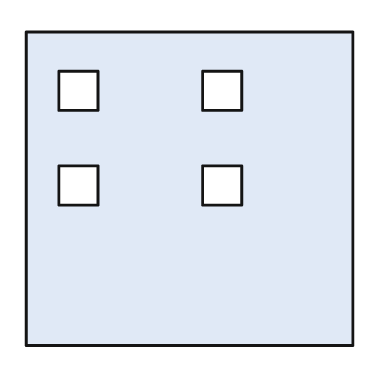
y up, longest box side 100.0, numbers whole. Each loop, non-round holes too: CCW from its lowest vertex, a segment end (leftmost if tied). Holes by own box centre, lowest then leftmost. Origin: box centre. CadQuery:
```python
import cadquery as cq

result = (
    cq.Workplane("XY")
    .moveTo(-50.0, -48.0)
    .lineTo(50.0, -48.0)
    .lineTo(50.0, 48.0)
    .lineTo(-50.0, 48.0)
    .close()
    .moveTo(-40.0, -5.0)
    .lineTo(-28.0, -5.0)
    .lineTo(-28.0, 7.0)
    .lineTo(-40.0, 7.0)
    .close()
    .moveTo(4.0, -5.0)
    .lineTo(16.0, -5.0)
    .lineTo(16.0, 7.0)
    .lineTo(4.0, 7.0)
    .close()
    .moveTo(-40.0, 24.0)
    .lineTo(-28.0, 24.0)
    .lineTo(-28.0, 36.0)
    .lineTo(-40.0, 36.0)
    .close()
    .moveTo(4.0, 24.0)
    .lineTo(16.0, 24.0)
    .lineTo(16.0, 36.0)
    .lineTo(4.0, 36.0)
    .close()
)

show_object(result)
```